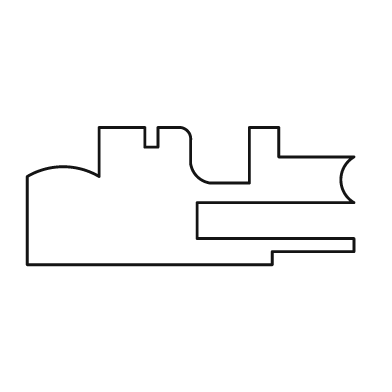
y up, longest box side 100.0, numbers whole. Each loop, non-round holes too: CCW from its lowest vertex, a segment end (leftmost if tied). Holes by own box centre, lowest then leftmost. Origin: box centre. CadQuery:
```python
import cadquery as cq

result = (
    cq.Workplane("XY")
    .moveTo(-50.0, -21.0)
    .lineTo(25.0, -21.0)
    .lineTo(25.0, -17.0)
    .lineTo(50.0, -17.0)
    .lineTo(50.0, -13.0)
    .lineTo(2.0, -13.0)
    .lineTo(2.0, -2.0)
    .lineTo(50.0, -2.0)
    .threePointArc((46.0, 5.0), (50.0, 12.0))
    .lineTo(27.0, 12.0)
    .lineTo(27.0, 21.0)
    .lineTo(18.0, 21.0)
    .lineTo(18.0, 4.0)
    .lineTo(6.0, 4.0)
    .threePointArc((2.0, 6.0), (0.0, 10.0))
    .lineTo(0.0, 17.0)
    .threePointArc((-1.0, 20.0), (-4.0, 21.0))
    .lineTo(-10.0, 21.0)
    .lineTo(-10.0, 15.0)
    .lineTo(-14.0, 15.0)
    .lineTo(-14.0, 21.0)
    .lineTo(-28.0, 21.0)
    .lineTo(-28.0, 6.0)
    .threePointArc((-39.0, 9.0), (-50.0, 6.0))
    .close()
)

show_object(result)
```